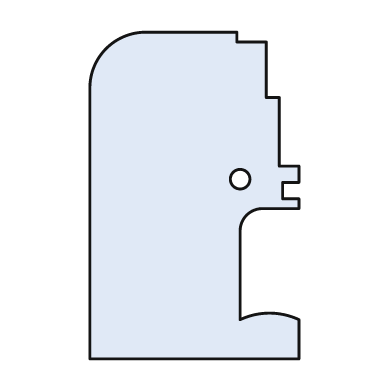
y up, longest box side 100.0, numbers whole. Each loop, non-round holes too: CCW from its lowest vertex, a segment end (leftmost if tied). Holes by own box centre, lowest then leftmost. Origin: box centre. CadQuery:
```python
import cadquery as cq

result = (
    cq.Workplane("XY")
    .moveTo(-32.0, -50.0)
    .lineTo(32.0, -50.0)
    .lineTo(32.0, -38.0)
    .threePointArc((23.0, -36.0), (14.0, -38.0))
    .lineTo(14.0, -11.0)
    .threePointArc((16.0, -6.0), (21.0, -4.0))
    .lineTo(32.0, -4.0)
    .lineTo(32.0, -1.0)
    .lineTo(27.0, -1.0)
    .lineTo(27.0, 4.0)
    .lineTo(32.0, 4.0)
    .lineTo(32.0, 9.0)
    .lineTo(26.0, 9.0)
    .lineTo(26.0, 30.0)
    .lineTo(22.0, 30.0)
    .lineTo(22.0, 47.0)
    .lineTo(13.0, 47.0)
    .lineTo(13.0, 50.0)
    .lineTo(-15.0, 50.0)
    .threePointArc((-27.0, 45.0), (-32.0, 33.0))
    .close()
    .moveTo(14.0, 5.0)
    .circle(3.0)
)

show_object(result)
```